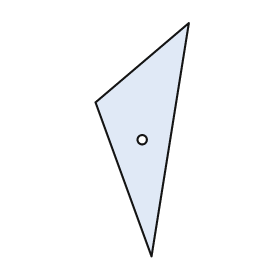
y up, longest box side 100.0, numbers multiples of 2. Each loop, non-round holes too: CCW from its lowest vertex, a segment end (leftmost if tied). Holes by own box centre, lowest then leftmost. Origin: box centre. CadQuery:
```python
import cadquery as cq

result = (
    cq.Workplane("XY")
    .moveTo(4.0, -50.0)
    .lineTo(20.0, 50.0)
    .lineTo(-20.0, 16.0)
    .close()
    .moveTo(0.0, 0.0)
    .circle(2.0)
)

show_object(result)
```